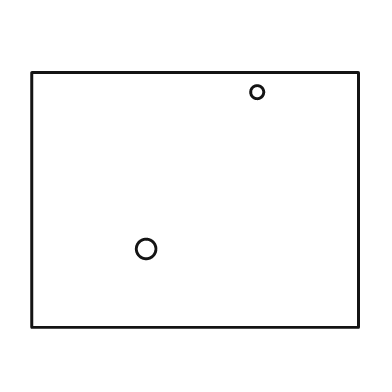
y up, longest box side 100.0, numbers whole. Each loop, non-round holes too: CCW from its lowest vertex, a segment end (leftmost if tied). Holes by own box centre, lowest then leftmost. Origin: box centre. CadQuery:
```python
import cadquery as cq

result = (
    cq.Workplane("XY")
    .moveTo(-50.0, -39.0)
    .lineTo(50.0, -39.0)
    .lineTo(50.0, 39.0)
    .lineTo(-50.0, 39.0)
    .close()
    .moveTo(-15.0, -15.0)
    .circle(3.0)
    .moveTo(19.0, 33.0)
    .circle(2.0)
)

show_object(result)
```